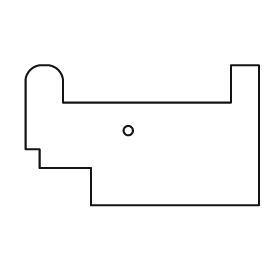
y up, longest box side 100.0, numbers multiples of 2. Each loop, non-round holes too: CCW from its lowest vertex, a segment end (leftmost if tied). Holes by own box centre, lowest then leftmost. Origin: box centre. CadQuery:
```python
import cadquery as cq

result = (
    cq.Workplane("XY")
    .moveTo(-22.0, -30.0)
    .lineTo(50.0, -30.0)
    .lineTo(50.0, 30.0)
    .lineTo(38.0, 30.0)
    .lineTo(38.0, 14.0)
    .lineTo(-34.0, 14.0)
    .lineTo(-34.0, 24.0)
    .threePointArc((-36.0, 28.0), (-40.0, 30.0))
    .lineTo(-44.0, 30.0)
    .threePointArc((-48.0, 28.0), (-50.0, 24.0))
    .lineTo(-50.0, -6.0)
    .lineTo(-44.0, -6.0)
    .lineTo(-44.0, -14.0)
    .lineTo(-22.0, -14.0)
    .close()
    .moveTo(-6.0, 2.0)
    .circle(2.0)
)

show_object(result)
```